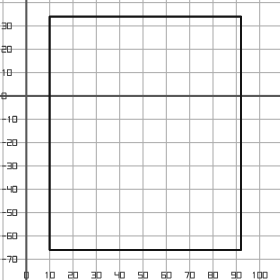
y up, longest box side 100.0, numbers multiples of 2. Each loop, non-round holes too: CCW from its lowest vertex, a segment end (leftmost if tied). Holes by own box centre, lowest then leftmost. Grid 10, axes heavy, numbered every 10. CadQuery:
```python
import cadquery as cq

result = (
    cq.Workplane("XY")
    .moveTo(10.0, -66.0)
    .lineTo(92.0, -66.0)
    .lineTo(92.0, 34.0)
    .lineTo(10.0, 34.0)
    .close()
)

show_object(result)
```